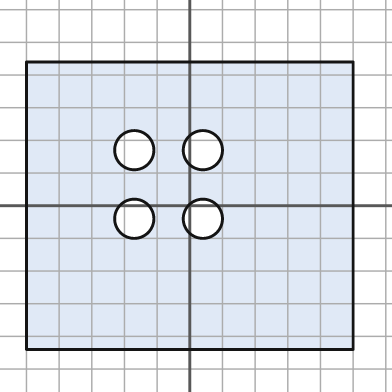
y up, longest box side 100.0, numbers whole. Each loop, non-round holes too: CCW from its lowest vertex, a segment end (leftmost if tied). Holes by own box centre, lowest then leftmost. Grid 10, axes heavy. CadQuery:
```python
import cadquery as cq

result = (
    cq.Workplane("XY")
    .moveTo(-50.0, -44.0)
    .lineTo(50.0, -44.0)
    .lineTo(50.0, 44.0)
    .lineTo(-50.0, 44.0)
    .close()
    .moveTo(-17.0, -4.0)
    .circle(6.0)
    .moveTo(4.0, -4.0)
    .circle(6.0)
    .moveTo(-17.0, 17.0)
    .circle(6.0)
    .moveTo(4.0, 17.0)
    .circle(6.0)
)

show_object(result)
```